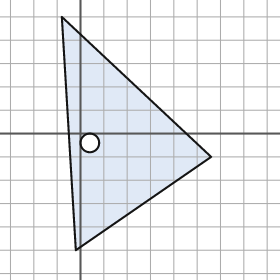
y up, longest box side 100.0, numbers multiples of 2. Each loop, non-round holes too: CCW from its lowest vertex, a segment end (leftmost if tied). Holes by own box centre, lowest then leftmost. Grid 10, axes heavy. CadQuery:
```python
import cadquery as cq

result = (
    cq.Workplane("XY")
    .moveTo(-2.0, -50.0)
    .lineTo(56.0, -10.0)
    .lineTo(-8.0, 50.0)
    .close()
    .moveTo(4.0, -4.0)
    .circle(4.0)
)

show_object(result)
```